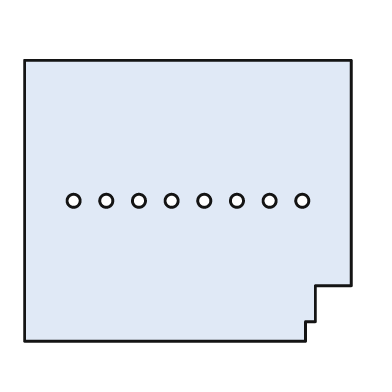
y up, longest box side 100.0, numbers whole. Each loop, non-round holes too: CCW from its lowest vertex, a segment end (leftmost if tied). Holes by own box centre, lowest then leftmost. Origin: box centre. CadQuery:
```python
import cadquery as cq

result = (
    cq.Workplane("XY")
    .moveTo(-50.0, -43.0)
    .lineTo(36.0, -43.0)
    .lineTo(36.0, -37.0)
    .lineTo(39.0, -37.0)
    .lineTo(39.0, -26.0)
    .lineTo(50.0, -26.0)
    .lineTo(50.0, 43.0)
    .lineTo(-50.0, 43.0)
    .close()
    .moveTo(-35.0, 0.0)
    .circle(2.0)
    .moveTo(-25.0, 0.0)
    .circle(2.0)
    .moveTo(-15.0, 0.0)
    .circle(2.0)
    .moveTo(-5.0, 0.0)
    .circle(2.0)
    .moveTo(5.0, 0.0)
    .circle(2.0)
    .moveTo(15.0, 0.0)
    .circle(2.0)
    .moveTo(25.0, 0.0)
    .circle(2.0)
    .moveTo(35.0, 0.0)
    .circle(2.0)
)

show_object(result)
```